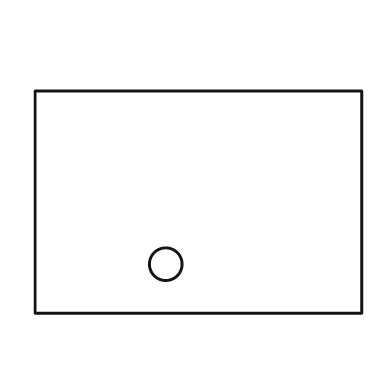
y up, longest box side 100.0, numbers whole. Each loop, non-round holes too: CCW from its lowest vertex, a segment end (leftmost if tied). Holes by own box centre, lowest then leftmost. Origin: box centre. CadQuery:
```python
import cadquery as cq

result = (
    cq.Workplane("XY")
    .moveTo(-50.0, -34.0)
    .lineTo(50.0, -34.0)
    .lineTo(50.0, 34.0)
    .lineTo(-50.0, 34.0)
    .close()
    .moveTo(-10.0, -19.0)
    .circle(5.0)
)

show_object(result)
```